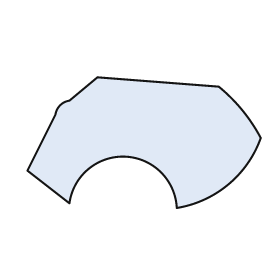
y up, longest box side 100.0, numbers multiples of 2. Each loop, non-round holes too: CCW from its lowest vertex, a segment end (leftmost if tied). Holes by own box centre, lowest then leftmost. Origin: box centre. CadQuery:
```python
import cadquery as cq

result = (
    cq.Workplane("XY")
    .moveTo(14.0, -28.0)
    .threePointArc((36.0, -18.0), (50.0, 2.0))
    .threePointArc((42.0, 14.0), (32.0, 24.0))
    .lineTo(-20.0, 28.0)
    .lineTo(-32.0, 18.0)
    .threePointArc((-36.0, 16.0), (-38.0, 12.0))
    .lineTo(-50.0, -12.0)
    .lineTo(-32.0, -26.0)
    .threePointArc((-8.0, -6.0), (14.0, -28.0))
    .close()
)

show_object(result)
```